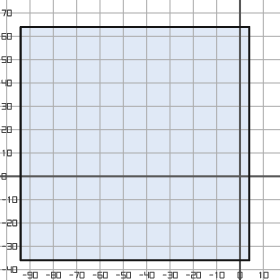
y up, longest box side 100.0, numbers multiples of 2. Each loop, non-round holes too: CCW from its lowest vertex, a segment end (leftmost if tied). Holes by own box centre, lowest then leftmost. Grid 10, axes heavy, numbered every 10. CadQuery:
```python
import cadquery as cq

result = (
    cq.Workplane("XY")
    .moveTo(-94.0, -36.0)
    .lineTo(4.0, -36.0)
    .lineTo(4.0, 64.0)
    .lineTo(-94.0, 64.0)
    .close()
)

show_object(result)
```